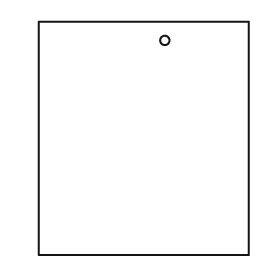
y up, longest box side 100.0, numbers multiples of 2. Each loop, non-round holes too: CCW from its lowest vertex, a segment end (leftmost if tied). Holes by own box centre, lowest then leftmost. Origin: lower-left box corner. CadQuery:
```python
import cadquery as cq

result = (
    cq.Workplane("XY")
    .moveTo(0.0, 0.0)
    .lineTo(90.0, 0.0)
    .lineTo(90.0, 100.0)
    .lineTo(0.0, 100.0)
    .close()
    .moveTo(54.0, 92.0)
    .circle(2.0)
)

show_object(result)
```